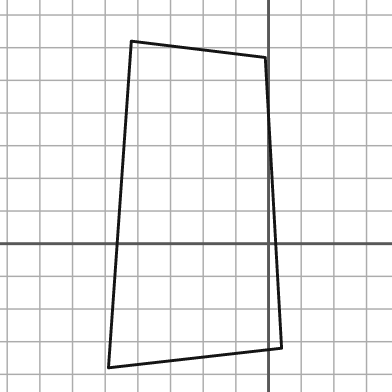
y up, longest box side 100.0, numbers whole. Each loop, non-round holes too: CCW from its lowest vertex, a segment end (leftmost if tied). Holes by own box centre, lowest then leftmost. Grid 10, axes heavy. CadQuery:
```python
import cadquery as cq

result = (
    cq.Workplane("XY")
    .moveTo(-49.0, -38.0)
    .lineTo(4.0, -32.0)
    .lineTo(-1.0, 57.0)
    .lineTo(-42.0, 62.0)
    .close()
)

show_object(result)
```